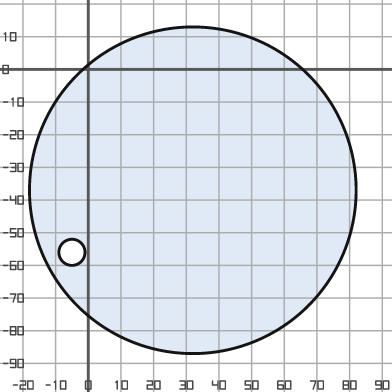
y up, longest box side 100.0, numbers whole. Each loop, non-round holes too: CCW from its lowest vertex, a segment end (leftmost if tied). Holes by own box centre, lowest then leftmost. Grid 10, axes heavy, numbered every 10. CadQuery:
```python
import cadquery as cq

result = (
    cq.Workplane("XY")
    .moveTo(32.0, -37.0)
    .circle(50.0)
    .moveTo(-5.0, -56.0)
    .circle(4.0)
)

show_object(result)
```